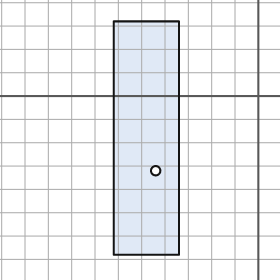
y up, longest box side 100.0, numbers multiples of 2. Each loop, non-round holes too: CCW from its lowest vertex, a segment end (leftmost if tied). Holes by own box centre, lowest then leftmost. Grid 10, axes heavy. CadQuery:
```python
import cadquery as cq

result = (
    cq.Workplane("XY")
    .moveTo(-62.0, -68.0)
    .lineTo(-34.0, -68.0)
    .lineTo(-34.0, 32.0)
    .lineTo(-62.0, 32.0)
    .close()
    .moveTo(-44.0, -32.0)
    .circle(2.0)
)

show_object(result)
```